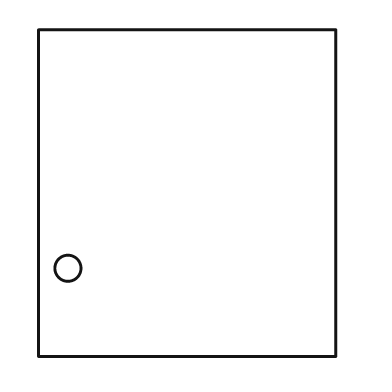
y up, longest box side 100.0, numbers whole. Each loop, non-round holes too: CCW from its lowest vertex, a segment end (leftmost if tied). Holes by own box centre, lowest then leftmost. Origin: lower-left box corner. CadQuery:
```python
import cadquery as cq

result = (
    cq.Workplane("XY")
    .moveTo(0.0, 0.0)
    .lineTo(91.0, 0.0)
    .lineTo(91.0, 100.0)
    .lineTo(0.0, 100.0)
    .close()
    .moveTo(9.0, 27.0)
    .circle(4.0)
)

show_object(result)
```